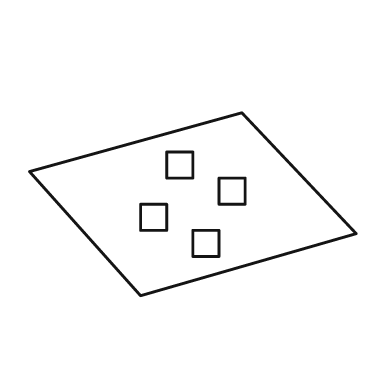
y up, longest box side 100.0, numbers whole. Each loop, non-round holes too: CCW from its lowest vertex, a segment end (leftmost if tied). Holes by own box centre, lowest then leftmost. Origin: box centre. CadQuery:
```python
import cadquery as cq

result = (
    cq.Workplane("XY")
    .moveTo(-16.0, -28.0)
    .lineTo(50.0, -9.0)
    .lineTo(15.0, 28.0)
    .lineTo(-50.0, 10.0)
    .close()
    .moveTo(0.0, -16.0)
    .lineTo(8.0, -16.0)
    .lineTo(8.0, -8.0)
    .lineTo(0.0, -8.0)
    .close()
    .moveTo(-16.0, -8.0)
    .lineTo(-8.0, -8.0)
    .lineTo(-8.0, 0.0)
    .lineTo(-16.0, 0.0)
    .close()
    .moveTo(8.0, 0.0)
    .lineTo(16.0, 0.0)
    .lineTo(16.0, 8.0)
    .lineTo(8.0, 8.0)
    .close()
    .moveTo(-8.0, 8.0)
    .lineTo(0.0, 8.0)
    .lineTo(0.0, 16.0)
    .lineTo(-8.0, 16.0)
    .close()
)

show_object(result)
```